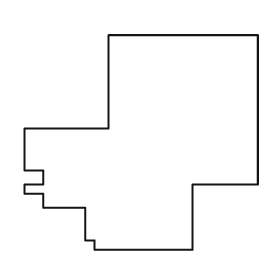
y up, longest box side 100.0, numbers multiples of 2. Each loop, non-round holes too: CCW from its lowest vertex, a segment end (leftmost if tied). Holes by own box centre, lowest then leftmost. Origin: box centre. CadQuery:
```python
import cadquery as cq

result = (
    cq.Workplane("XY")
    .moveTo(-20.0, -46.0)
    .lineTo(22.0, -46.0)
    .lineTo(22.0, -18.0)
    .lineTo(50.0, -18.0)
    .lineTo(50.0, 46.0)
    .lineTo(-14.0, 46.0)
    .lineTo(-14.0, 6.0)
    .lineTo(-50.0, 6.0)
    .lineTo(-50.0, -12.0)
    .lineTo(-42.0, -12.0)
    .lineTo(-42.0, -18.0)
    .lineTo(-50.0, -18.0)
    .lineTo(-50.0, -22.0)
    .lineTo(-42.0, -22.0)
    .lineTo(-42.0, -28.0)
    .lineTo(-24.0, -28.0)
    .lineTo(-24.0, -42.0)
    .lineTo(-20.0, -42.0)
    .close()
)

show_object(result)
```